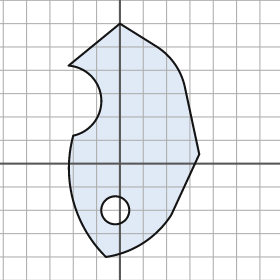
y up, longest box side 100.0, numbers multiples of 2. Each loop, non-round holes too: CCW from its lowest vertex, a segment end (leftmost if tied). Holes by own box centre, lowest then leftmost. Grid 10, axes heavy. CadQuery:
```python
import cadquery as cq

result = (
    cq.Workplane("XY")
    .moveTo(-6.0, -40.0)
    .threePointArc((10.0, -34.0), (22.0, -22.0))
    .lineTo(34.0, 4.0)
    .lineTo(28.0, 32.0)
    .threePointArc((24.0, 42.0), (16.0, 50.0))
    .lineTo(0.0, 60.0)
    .lineTo(-22.0, 42.0)
    .threePointArc((-8.0, 28.0), (-20.0, 12.0))
    .threePointArc((-20.0, -16.0), (-6.0, -40.0))
    .close()
    .moveTo(-2.0, -20.0)
    .circle(6.0)
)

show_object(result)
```